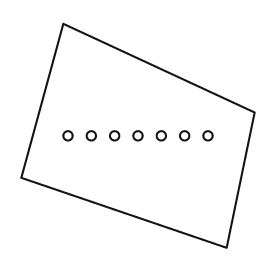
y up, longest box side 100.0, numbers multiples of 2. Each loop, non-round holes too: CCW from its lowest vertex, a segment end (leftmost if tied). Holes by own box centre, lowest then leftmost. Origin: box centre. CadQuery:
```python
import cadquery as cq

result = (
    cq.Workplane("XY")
    .moveTo(38.0, -48.0)
    .lineTo(50.0, 10.0)
    .lineTo(-32.0, 48.0)
    .lineTo(-50.0, -18.0)
    .close()
    .moveTo(-30.0, 0.0)
    .circle(2.0)
    .moveTo(-20.0, 0.0)
    .circle(2.0)
    .moveTo(-10.0, 0.0)
    .circle(2.0)
    .moveTo(0.0, 0.0)
    .circle(2.0)
    .moveTo(10.0, 0.0)
    .circle(2.0)
    .moveTo(20.0, 0.0)
    .circle(2.0)
    .moveTo(30.0, 0.0)
    .circle(2.0)
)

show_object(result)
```